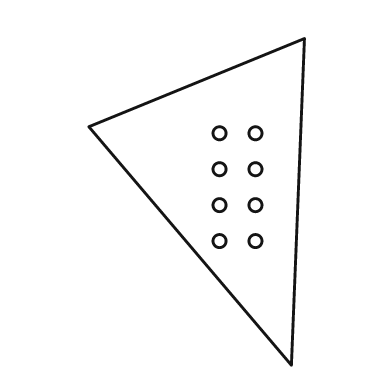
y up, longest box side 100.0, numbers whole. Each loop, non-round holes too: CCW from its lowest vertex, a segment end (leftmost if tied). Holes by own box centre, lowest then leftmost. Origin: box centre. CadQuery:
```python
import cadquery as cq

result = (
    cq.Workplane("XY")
    .moveTo(29.0, -50.0)
    .lineTo(33.0, 50.0)
    .lineTo(-33.0, 23.0)
    .close()
    .moveTo(7.0, -12.0)
    .circle(2.0)
    .moveTo(18.0, -12.0)
    .circle(2.0)
    .moveTo(7.0, -1.0)
    .circle(2.0)
    .moveTo(18.0, -1.0)
    .circle(2.0)
    .moveTo(7.0, 10.0)
    .circle(2.0)
    .moveTo(18.0, 10.0)
    .circle(2.0)
    .moveTo(7.0, 21.0)
    .circle(2.0)
    .moveTo(18.0, 21.0)
    .circle(2.0)
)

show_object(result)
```